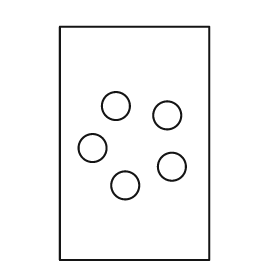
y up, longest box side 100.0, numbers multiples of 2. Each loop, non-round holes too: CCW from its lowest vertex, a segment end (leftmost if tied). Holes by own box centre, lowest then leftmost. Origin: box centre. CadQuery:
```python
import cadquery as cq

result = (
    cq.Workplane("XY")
    .moveTo(-32.0, -50.0)
    .lineTo(32.0, -50.0)
    .lineTo(32.0, 50.0)
    .lineTo(-32.0, 50.0)
    .close()
    .moveTo(-4.0, -18.0)
    .circle(6.0)
    .moveTo(16.0, -10.0)
    .circle(6.0)
    .moveTo(-18.0, -2.0)
    .circle(6.0)
    .moveTo(14.0, 12.0)
    .circle(6.0)
    .moveTo(-8.0, 16.0)
    .circle(6.0)
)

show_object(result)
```